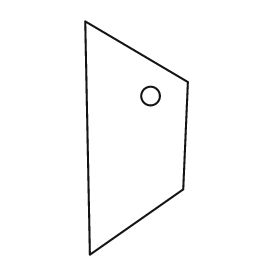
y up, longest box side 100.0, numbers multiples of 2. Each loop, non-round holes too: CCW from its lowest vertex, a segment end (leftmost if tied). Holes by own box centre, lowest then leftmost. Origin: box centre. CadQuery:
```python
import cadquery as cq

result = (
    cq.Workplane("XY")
    .moveTo(-20.0, -50.0)
    .lineTo(20.0, -22.0)
    .lineTo(22.0, 24.0)
    .lineTo(-22.0, 50.0)
    .close()
    .moveTo(6.0, 18.0)
    .circle(4.0)
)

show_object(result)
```